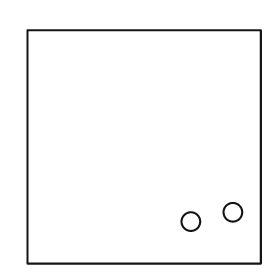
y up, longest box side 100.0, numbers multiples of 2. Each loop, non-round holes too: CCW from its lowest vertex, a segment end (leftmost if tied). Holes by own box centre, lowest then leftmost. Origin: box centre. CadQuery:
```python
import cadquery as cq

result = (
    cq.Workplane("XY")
    .moveTo(-50.0, -50.0)
    .lineTo(50.0, -50.0)
    .lineTo(50.0, 50.0)
    .lineTo(-50.0, 50.0)
    .close()
    .moveTo(20.0, -32.0)
    .circle(4.0)
    .moveTo(38.0, -28.0)
    .circle(4.0)
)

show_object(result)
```